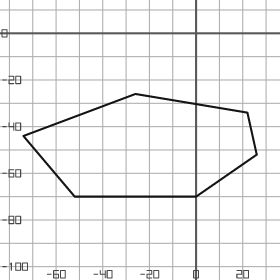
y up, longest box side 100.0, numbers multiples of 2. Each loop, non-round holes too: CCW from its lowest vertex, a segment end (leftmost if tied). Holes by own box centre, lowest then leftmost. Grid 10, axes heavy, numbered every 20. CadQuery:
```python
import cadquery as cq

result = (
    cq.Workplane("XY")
    .moveTo(-52.0, -70.0)
    .lineTo(0.0, -70.0)
    .lineTo(26.0, -52.0)
    .lineTo(22.0, -34.0)
    .lineTo(-26.0, -26.0)
    .lineTo(-74.0, -44.0)
    .close()
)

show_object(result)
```